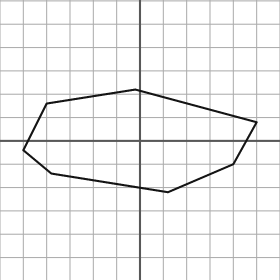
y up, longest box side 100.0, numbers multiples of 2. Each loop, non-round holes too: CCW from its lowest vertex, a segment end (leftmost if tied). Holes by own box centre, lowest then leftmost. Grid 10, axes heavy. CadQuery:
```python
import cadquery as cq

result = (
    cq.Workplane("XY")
    .moveTo(12.0, -22.0)
    .lineTo(40.0, -10.0)
    .lineTo(50.0, 8.0)
    .lineTo(-2.0, 22.0)
    .lineTo(-40.0, 16.0)
    .lineTo(-50.0, -4.0)
    .lineTo(-38.0, -14.0)
    .close()
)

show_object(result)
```